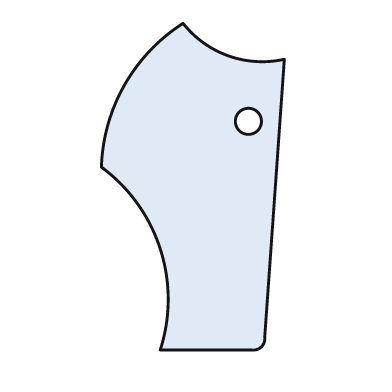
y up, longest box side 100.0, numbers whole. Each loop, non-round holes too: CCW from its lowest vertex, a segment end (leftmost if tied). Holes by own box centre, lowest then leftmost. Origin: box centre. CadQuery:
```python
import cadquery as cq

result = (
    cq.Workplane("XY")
    .moveTo(-10.0, -50.0)
    .lineTo(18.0, -50.0)
    .threePointArc((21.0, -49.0), (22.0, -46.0))
    .lineTo(28.0, 39.0)
    .threePointArc((11.0, 40.0), (-3.0, 50.0))
    .threePointArc((-21.0, 31.0), (-28.0, 6.0))
    .threePointArc((-10.0, -19.0), (-10.0, -50.0))
    .close()
    .moveTo(17.0, 20.0)
    .circle(4.0)
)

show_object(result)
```